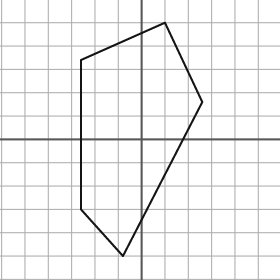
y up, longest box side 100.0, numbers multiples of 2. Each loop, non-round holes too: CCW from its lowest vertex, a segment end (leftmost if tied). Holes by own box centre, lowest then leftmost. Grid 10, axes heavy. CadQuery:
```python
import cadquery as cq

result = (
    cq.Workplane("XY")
    .moveTo(-8.0, -50.0)
    .lineTo(26.0, 16.0)
    .lineTo(10.0, 50.0)
    .lineTo(-26.0, 34.0)
    .lineTo(-26.0, -30.0)
    .close()
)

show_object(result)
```